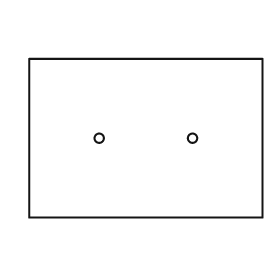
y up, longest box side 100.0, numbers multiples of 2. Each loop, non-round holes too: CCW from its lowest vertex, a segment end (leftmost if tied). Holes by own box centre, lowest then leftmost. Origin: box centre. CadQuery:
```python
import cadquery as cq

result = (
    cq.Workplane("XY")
    .moveTo(-50.0, -34.0)
    .lineTo(50.0, -34.0)
    .lineTo(50.0, 34.0)
    .lineTo(-50.0, 34.0)
    .close()
    .moveTo(-20.0, 0.0)
    .circle(2.0)
    .moveTo(20.0, 0.0)
    .circle(2.0)
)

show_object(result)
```